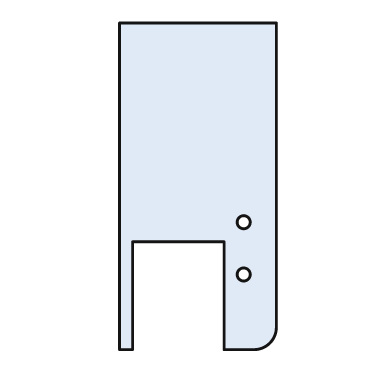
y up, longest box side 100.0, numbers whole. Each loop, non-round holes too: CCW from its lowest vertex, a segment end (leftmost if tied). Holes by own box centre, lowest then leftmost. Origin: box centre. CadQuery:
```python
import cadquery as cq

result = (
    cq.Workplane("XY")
    .moveTo(-24.0, -50.0)
    .lineTo(-20.0, -50.0)
    .lineTo(-20.0, -17.0)
    .lineTo(8.0, -17.0)
    .lineTo(8.0, -50.0)
    .lineTo(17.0, -50.0)
    .threePointArc((22.0, -48.0), (24.0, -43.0))
    .lineTo(24.0, 50.0)
    .lineTo(-24.0, 50.0)
    .close()
    .moveTo(14.0, -27.0)
    .circle(2.0)
    .moveTo(14.0, -11.0)
    .circle(2.0)
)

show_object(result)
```